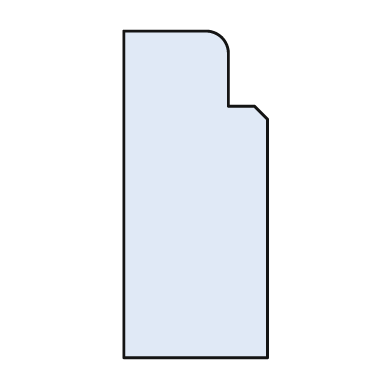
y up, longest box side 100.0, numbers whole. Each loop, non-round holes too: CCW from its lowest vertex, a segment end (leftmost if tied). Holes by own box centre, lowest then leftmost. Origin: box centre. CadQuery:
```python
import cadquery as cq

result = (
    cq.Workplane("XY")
    .moveTo(-22.0, -50.0)
    .lineTo(22.0, -50.0)
    .lineTo(22.0, 23.0)
    .lineTo(18.0, 27.0)
    .lineTo(10.0, 27.0)
    .lineTo(10.0, 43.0)
    .threePointArc((8.0, 48.0), (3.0, 50.0))
    .lineTo(-22.0, 50.0)
    .close()
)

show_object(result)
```